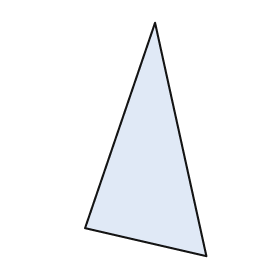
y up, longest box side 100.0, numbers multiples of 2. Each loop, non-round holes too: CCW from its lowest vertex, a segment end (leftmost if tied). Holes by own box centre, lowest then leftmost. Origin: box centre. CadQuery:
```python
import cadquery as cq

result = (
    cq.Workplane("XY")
    .moveTo(26.0, -50.0)
    .lineTo(4.0, 50.0)
    .lineTo(-26.0, -38.0)
    .close()
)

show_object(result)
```